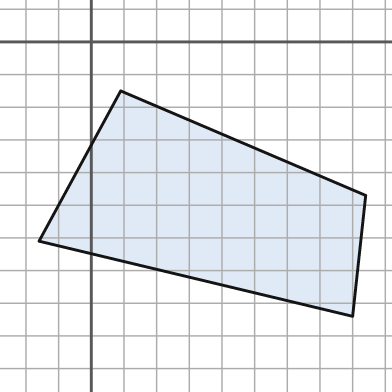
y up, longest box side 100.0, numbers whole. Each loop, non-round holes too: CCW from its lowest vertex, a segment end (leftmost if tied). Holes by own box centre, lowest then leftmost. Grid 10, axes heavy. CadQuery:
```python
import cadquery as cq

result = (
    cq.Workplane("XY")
    .moveTo(80.0, -84.0)
    .lineTo(84.0, -47.0)
    .lineTo(9.0, -15.0)
    .lineTo(-16.0, -61.0)
    .close()
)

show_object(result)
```